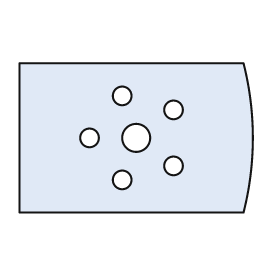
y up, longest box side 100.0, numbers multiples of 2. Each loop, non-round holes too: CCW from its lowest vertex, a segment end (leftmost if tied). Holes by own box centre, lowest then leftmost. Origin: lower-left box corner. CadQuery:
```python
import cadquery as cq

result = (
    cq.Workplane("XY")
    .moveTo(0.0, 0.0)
    .lineTo(96.0, 0.0)
    .threePointArc((100.0, 32.0), (96.0, 64.0))
    .lineTo(0.0, 64.0)
    .close()
    .moveTo(44.0, 14.0)
    .circle(4.0)
    .moveTo(66.0, 20.0)
    .circle(4.0)
    .moveTo(30.0, 32.0)
    .circle(4.0)
    .moveTo(50.0, 32.0)
    .circle(6.0)
    .moveTo(66.0, 44.0)
    .circle(4.0)
    .moveTo(44.0, 50.0)
    .circle(4.0)
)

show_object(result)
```